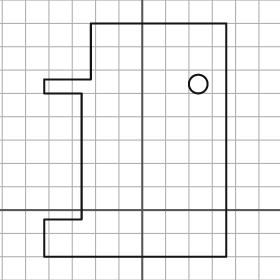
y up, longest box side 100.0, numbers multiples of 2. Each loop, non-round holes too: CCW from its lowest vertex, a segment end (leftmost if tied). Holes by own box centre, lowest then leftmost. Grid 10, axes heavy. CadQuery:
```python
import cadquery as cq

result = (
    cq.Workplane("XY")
    .moveTo(-42.0, -20.0)
    .lineTo(36.0, -20.0)
    .lineTo(36.0, 80.0)
    .lineTo(-22.0, 80.0)
    .lineTo(-22.0, 56.0)
    .lineTo(-42.0, 56.0)
    .lineTo(-42.0, 50.0)
    .lineTo(-26.0, 50.0)
    .lineTo(-26.0, -4.0)
    .lineTo(-42.0, -4.0)
    .close()
    .moveTo(24.0, 54.0)
    .circle(4.0)
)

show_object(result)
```